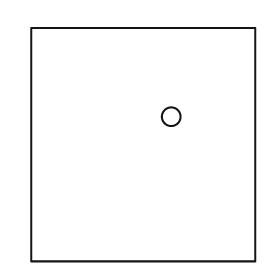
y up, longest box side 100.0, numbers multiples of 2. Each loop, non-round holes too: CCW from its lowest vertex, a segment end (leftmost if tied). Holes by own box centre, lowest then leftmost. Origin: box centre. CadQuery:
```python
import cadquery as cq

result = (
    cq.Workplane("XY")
    .moveTo(-48.0, -50.0)
    .lineTo(48.0, -50.0)
    .lineTo(48.0, 50.0)
    .lineTo(-48.0, 50.0)
    .close()
    .moveTo(12.0, 12.0)
    .circle(4.0)
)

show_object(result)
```